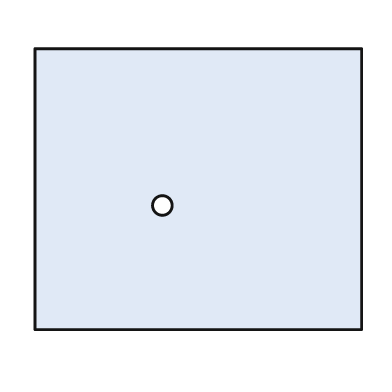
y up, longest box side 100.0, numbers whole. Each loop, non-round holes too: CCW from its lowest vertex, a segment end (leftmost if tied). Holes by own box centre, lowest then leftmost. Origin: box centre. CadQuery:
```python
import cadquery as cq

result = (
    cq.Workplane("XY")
    .moveTo(-50.0, -43.0)
    .lineTo(50.0, -43.0)
    .lineTo(50.0, 43.0)
    .lineTo(-50.0, 43.0)
    .close()
    .moveTo(-11.0, -5.0)
    .circle(3.0)
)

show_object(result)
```